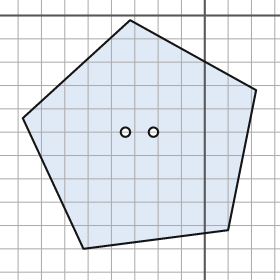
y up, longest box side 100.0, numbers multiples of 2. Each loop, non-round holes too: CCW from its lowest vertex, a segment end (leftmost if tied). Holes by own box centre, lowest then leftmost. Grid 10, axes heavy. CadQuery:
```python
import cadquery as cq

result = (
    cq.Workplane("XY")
    .moveTo(-52.0, -100.0)
    .lineTo(10.0, -92.0)
    .lineTo(22.0, -32.0)
    .lineTo(-32.0, -2.0)
    .lineTo(-78.0, -44.0)
    .close()
    .moveTo(-34.0, -50.0)
    .circle(2.0)
    .moveTo(-22.0, -50.0)
    .circle(2.0)
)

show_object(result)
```